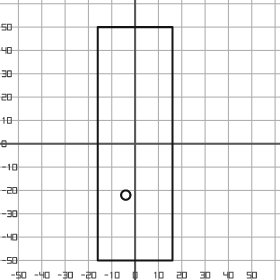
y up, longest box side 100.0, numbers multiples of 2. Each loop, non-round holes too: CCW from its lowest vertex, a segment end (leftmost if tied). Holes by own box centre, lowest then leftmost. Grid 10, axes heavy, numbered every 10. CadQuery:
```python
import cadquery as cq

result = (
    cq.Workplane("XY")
    .moveTo(-16.0, -50.0)
    .lineTo(16.0, -50.0)
    .lineTo(16.0, 50.0)
    .lineTo(-16.0, 50.0)
    .close()
    .moveTo(-4.0, -22.0)
    .circle(2.0)
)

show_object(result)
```